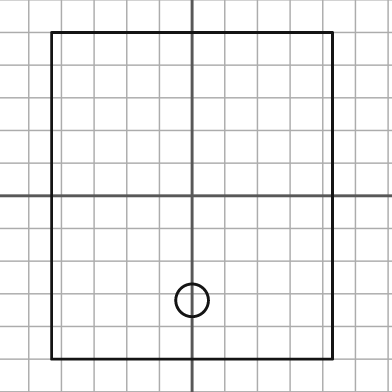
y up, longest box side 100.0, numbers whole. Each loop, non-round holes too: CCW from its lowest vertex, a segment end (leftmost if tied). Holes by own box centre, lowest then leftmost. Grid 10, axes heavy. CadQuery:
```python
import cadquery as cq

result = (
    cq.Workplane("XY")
    .moveTo(-43.0, -50.0)
    .lineTo(43.0, -50.0)
    .lineTo(43.0, 50.0)
    .lineTo(-43.0, 50.0)
    .close()
    .moveTo(0.0, -32.0)
    .circle(5.0)
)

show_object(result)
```